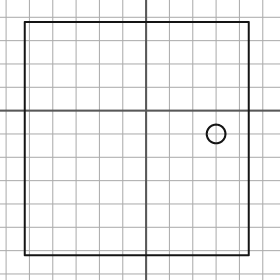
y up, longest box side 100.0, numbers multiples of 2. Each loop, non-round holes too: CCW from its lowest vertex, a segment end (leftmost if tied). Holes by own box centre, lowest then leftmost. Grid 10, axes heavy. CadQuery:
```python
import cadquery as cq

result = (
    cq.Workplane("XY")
    .moveTo(-52.0, -62.0)
    .lineTo(44.0, -62.0)
    .lineTo(44.0, 38.0)
    .lineTo(-52.0, 38.0)
    .close()
    .moveTo(30.0, -10.0)
    .circle(4.0)
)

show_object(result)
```